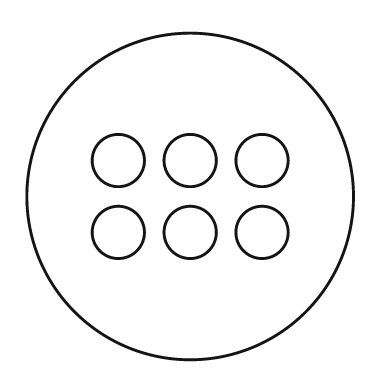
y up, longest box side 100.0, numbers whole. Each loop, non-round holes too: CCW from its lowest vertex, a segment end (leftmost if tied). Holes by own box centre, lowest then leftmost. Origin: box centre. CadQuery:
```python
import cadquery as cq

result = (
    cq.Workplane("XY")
    .moveTo(0.0, 0.0)
    .circle(50.0)
    .moveTo(-22.0, -11.0)
    .circle(8.0)
    .moveTo(0.0, -11.0)
    .circle(8.0)
    .moveTo(22.0, -11.0)
    .circle(8.0)
    .moveTo(-22.0, 11.0)
    .circle(8.0)
    .moveTo(0.0, 11.0)
    .circle(8.0)
    .moveTo(22.0, 11.0)
    .circle(8.0)
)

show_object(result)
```